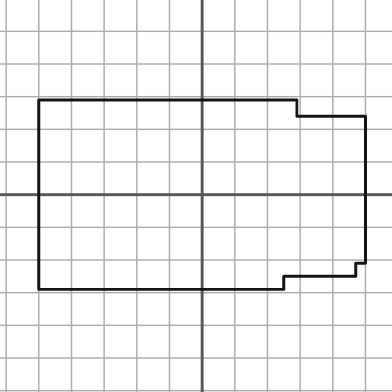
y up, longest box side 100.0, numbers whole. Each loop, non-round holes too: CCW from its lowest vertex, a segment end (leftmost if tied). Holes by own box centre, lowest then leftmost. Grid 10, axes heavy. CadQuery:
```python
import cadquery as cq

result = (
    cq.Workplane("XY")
    .moveTo(-50.0, -29.0)
    .lineTo(25.0, -29.0)
    .lineTo(25.0, -25.0)
    .lineTo(47.0, -25.0)
    .lineTo(47.0, -21.0)
    .lineTo(50.0, -21.0)
    .lineTo(50.0, 24.0)
    .lineTo(29.0, 24.0)
    .lineTo(29.0, 29.0)
    .lineTo(-50.0, 29.0)
    .close()
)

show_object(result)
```